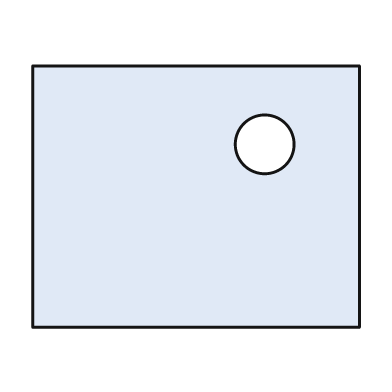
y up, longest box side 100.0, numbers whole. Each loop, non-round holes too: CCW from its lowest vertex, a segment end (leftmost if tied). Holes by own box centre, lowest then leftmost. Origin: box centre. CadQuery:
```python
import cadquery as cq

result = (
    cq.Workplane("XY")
    .moveTo(-50.0, -40.0)
    .lineTo(50.0, -40.0)
    .lineTo(50.0, 40.0)
    .lineTo(-50.0, 40.0)
    .close()
    .moveTo(21.0, 16.0)
    .circle(9.0)
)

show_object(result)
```